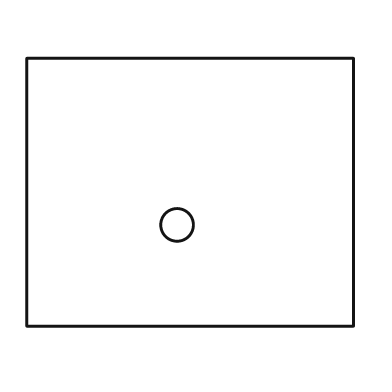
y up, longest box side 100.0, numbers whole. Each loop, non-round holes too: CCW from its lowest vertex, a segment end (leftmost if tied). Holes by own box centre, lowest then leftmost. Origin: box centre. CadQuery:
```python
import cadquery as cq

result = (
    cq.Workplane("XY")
    .moveTo(-50.0, -41.0)
    .lineTo(50.0, -41.0)
    .lineTo(50.0, 41.0)
    .lineTo(-50.0, 41.0)
    .close()
    .moveTo(-4.0, -10.0)
    .circle(5.0)
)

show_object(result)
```